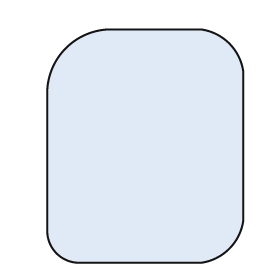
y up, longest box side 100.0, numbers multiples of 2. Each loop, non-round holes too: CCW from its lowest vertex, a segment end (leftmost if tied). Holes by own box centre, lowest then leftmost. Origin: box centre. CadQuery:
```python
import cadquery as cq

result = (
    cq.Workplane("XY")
    .moveTo(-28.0, -50.0)
    .lineTo(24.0, -50.0)
    .threePointArc((36.0, -44.0), (42.0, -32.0))
    .lineTo(42.0, 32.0)
    .threePointArc((36.0, 44.0), (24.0, 50.0))
    .lineTo(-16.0, 50.0)
    .threePointArc((-34.0, 42.0), (-42.0, 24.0))
    .lineTo(-42.0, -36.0)
    .threePointArc((-38.0, -46.0), (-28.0, -50.0))
    .close()
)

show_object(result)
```